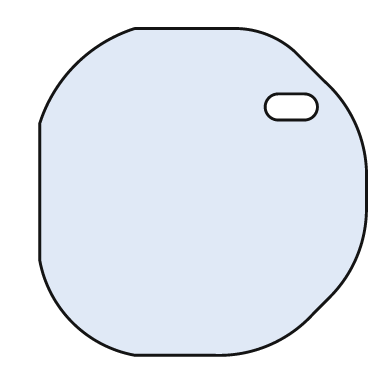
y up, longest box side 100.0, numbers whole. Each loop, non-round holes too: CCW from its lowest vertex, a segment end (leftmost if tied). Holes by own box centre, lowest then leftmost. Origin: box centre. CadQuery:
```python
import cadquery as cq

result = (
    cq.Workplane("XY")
    .moveTo(-21.0, -50.0)
    .lineTo(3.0, -50.0)
    .threePointArc((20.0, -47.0), (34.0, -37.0))
    .lineTo(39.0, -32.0)
    .threePointArc((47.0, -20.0), (50.0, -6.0))
    .lineTo(50.0, 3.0)
    .threePointArc((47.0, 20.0), (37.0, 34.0))
    .lineTo(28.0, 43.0)
    .threePointArc((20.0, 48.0), (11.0, 50.0))
    .lineTo(-21.0, 50.0)
    .threePointArc((-39.0, 39.0), (-50.0, 21.0))
    .lineTo(-50.0, -21.0)
    .threePointArc((-40.0, -40.0), (-21.0, -50.0))
    .close()
    .moveTo(23.0, 22.0)
    .lineTo(31.0, 22.0)
    .threePointArc((35.0, 26.0), (31.0, 30.0))
    .lineTo(23.0, 30.0)
    .threePointArc((19.0, 26.0), (23.0, 22.0))
    .close()
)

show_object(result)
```